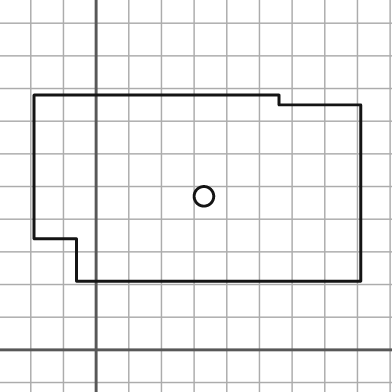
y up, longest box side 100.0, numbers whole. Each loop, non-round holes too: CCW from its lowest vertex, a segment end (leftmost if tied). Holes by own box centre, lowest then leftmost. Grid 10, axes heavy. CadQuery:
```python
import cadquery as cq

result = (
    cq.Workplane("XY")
    .moveTo(-6.0, 21.0)
    .lineTo(81.0, 21.0)
    .lineTo(81.0, 75.0)
    .lineTo(56.0, 75.0)
    .lineTo(56.0, 78.0)
    .lineTo(-19.0, 78.0)
    .lineTo(-19.0, 34.0)
    .lineTo(-6.0, 34.0)
    .close()
    .moveTo(33.0, 47.0)
    .circle(3.0)
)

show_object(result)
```